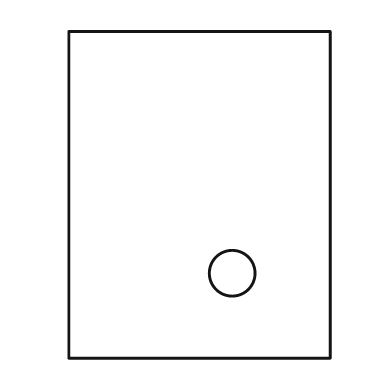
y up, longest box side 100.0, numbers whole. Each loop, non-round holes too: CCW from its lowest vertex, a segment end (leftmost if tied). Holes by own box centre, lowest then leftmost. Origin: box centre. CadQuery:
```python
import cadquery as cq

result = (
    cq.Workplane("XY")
    .moveTo(-40.0, -50.0)
    .lineTo(40.0, -50.0)
    .lineTo(40.0, 50.0)
    .lineTo(-40.0, 50.0)
    .close()
    .moveTo(10.0, -24.0)
    .circle(7.0)
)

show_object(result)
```